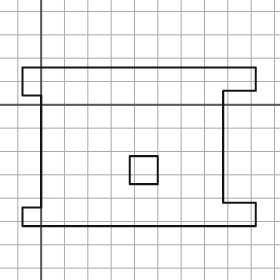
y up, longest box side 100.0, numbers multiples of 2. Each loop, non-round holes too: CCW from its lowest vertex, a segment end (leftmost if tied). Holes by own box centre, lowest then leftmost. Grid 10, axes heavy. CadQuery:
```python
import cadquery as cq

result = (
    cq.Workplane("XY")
    .moveTo(-8.0, -52.0)
    .lineTo(92.0, -52.0)
    .lineTo(92.0, -42.0)
    .lineTo(78.0, -42.0)
    .lineTo(78.0, 6.0)
    .lineTo(92.0, 6.0)
    .lineTo(92.0, 16.0)
    .lineTo(-8.0, 16.0)
    .lineTo(-8.0, 4.0)
    .lineTo(0.0, 4.0)
    .lineTo(0.0, -44.0)
    .lineTo(-8.0, -44.0)
    .close()
    .moveTo(38.0, -34.0)
    .lineTo(50.0, -34.0)
    .lineTo(50.0, -22.0)
    .lineTo(38.0, -22.0)
    .close()
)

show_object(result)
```